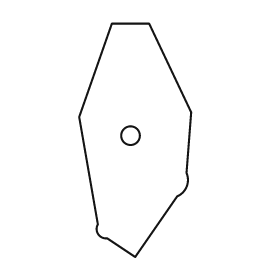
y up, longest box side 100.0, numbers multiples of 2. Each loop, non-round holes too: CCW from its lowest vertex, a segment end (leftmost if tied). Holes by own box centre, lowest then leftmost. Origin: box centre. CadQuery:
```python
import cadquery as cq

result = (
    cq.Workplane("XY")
    .moveTo(0.0, -50.0)
    .lineTo(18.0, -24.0)
    .threePointArc((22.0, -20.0), (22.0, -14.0))
    .lineTo(24.0, 12.0)
    .lineTo(6.0, 50.0)
    .lineTo(-10.0, 50.0)
    .lineTo(-24.0, 10.0)
    .lineTo(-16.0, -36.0)
    .threePointArc((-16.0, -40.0), (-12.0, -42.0))
    .close()
    .moveTo(-2.0, 2.0)
    .circle(4.0)
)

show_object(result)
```